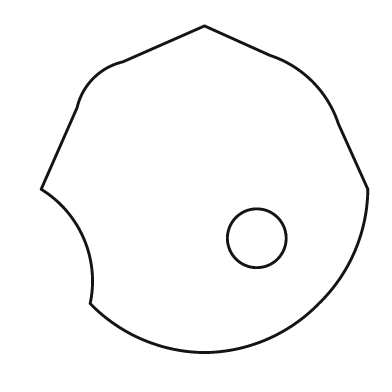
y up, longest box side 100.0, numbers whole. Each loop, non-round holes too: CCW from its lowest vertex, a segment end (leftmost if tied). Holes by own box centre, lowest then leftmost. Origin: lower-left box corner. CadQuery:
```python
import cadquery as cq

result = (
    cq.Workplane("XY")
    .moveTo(50.0, 0.0)
    .threePointArc((69.0, 4.0), (85.0, 15.0))
    .threePointArc((96.0, 31.0), (100.0, 50.0))
    .lineTo(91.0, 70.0)
    .threePointArc((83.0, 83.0), (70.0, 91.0))
    .lineTo(50.0, 100.0)
    .lineTo(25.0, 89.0)
    .threePointArc((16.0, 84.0), (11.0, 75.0))
    .lineTo(0.0, 50.0)
    .threePointArc((13.0, 35.0), (15.0, 15.0))
    .threePointArc((31.0, 4.0), (50.0, 0.0))
    .close()
    .moveTo(66.0, 35.0)
    .circle(9.0)
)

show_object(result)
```